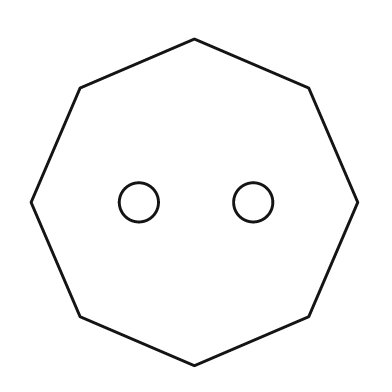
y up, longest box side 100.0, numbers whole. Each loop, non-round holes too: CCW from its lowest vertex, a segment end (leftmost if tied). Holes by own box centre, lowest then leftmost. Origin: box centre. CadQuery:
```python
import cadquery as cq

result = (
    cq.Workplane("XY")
    .moveTo(0.0, -50.0)
    .lineTo(35.0, -35.0)
    .lineTo(50.0, 0.0)
    .lineTo(35.0, 35.0)
    .lineTo(0.0, 50.0)
    .lineTo(-35.0, 35.0)
    .lineTo(-50.0, 0.0)
    .lineTo(-35.0, -35.0)
    .close()
    .moveTo(-17.0, 0.0)
    .circle(6.0)
    .moveTo(18.0, 0.0)
    .circle(6.0)
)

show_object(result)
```